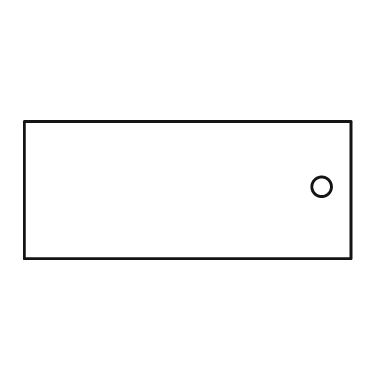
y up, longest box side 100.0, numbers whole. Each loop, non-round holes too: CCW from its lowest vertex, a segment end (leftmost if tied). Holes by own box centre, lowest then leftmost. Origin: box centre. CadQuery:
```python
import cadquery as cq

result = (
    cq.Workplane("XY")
    .moveTo(-50.0, -21.0)
    .lineTo(50.0, -21.0)
    .lineTo(50.0, 21.0)
    .lineTo(-50.0, 21.0)
    .close()
    .moveTo(41.0, 1.0)
    .circle(3.0)
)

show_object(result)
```